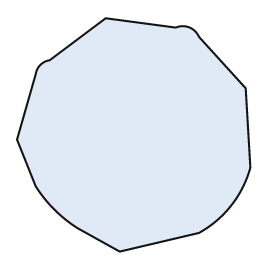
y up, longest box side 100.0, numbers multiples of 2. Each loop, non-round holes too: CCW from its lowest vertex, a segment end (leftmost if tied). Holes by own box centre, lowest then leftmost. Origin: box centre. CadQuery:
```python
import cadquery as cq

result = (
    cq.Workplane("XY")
    .moveTo(-6.0, -50.0)
    .lineTo(28.0, -42.0)
    .threePointArc((42.0, -30.0), (50.0, -14.0))
    .lineTo(48.0, 20.0)
    .lineTo(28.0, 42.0)
    .threePointArc((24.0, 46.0), (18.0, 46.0))
    .lineTo(-12.0, 50.0)
    .lineTo(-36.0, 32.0)
    .threePointArc((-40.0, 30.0), (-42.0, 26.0))
    .lineTo(-50.0, -2.0)
    .lineTo(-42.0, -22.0)
    .threePointArc((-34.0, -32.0), (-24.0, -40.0))
    .close()
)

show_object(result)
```